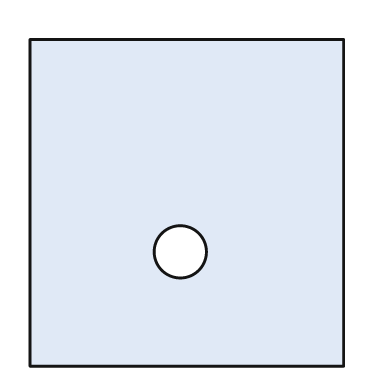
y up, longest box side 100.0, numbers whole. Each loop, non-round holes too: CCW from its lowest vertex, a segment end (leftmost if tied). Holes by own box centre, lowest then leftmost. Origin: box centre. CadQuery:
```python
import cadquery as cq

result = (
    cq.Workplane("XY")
    .moveTo(-48.0, -50.0)
    .lineTo(48.0, -50.0)
    .lineTo(48.0, 50.0)
    .lineTo(-48.0, 50.0)
    .close()
    .moveTo(-2.0, -15.0)
    .circle(8.0)
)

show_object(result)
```